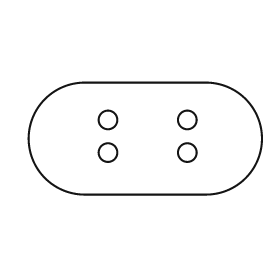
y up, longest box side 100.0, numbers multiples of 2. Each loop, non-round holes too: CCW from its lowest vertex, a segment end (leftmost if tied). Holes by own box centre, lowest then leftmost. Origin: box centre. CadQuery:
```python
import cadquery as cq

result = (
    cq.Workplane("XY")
    .moveTo(-26.0, -24.0)
    .lineTo(26.0, -24.0)
    .threePointArc((50.0, 0.0), (26.0, 24.0))
    .lineTo(-26.0, 24.0)
    .threePointArc((-50.0, 0.0), (-26.0, -24.0))
    .close()
    .moveTo(-16.0, -6.0)
    .circle(4.0)
    .moveTo(18.0, -6.0)
    .circle(4.0)
    .moveTo(-16.0, 8.0)
    .circle(4.0)
    .moveTo(18.0, 8.0)
    .circle(4.0)
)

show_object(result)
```